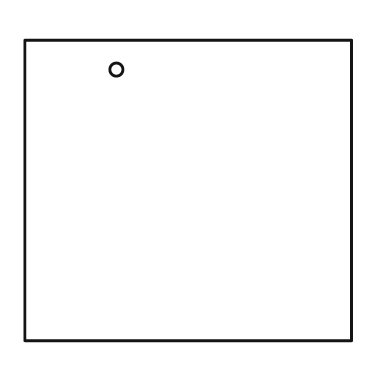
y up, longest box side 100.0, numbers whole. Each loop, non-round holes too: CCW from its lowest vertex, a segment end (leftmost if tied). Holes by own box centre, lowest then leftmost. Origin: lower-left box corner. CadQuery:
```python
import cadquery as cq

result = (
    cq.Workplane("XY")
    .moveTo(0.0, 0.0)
    .lineTo(100.0, 0.0)
    .lineTo(100.0, 92.0)
    .lineTo(0.0, 92.0)
    .close()
    .moveTo(28.0, 83.0)
    .circle(2.0)
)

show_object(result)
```